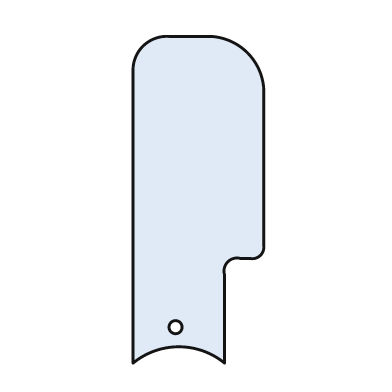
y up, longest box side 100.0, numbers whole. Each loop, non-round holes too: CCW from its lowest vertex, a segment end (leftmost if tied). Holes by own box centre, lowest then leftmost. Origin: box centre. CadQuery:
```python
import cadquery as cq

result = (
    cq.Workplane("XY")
    .moveTo(-20.0, -50.0)
    .threePointArc((-6.0, -45.0), (8.0, -50.0))
    .lineTo(8.0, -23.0)
    .threePointArc((9.0, -19.0), (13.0, -18.0))
    .lineTo(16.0, -18.0)
    .threePointArc((19.0, -17.0), (20.0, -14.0))
    .lineTo(20.0, 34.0)
    .threePointArc((15.0, 45.0), (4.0, 50.0))
    .lineTo(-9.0, 50.0)
    .threePointArc((-17.0, 47.0), (-20.0, 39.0))
    .close()
    .moveTo(-7.0, -39.0)
    .circle(2.0)
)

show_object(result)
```